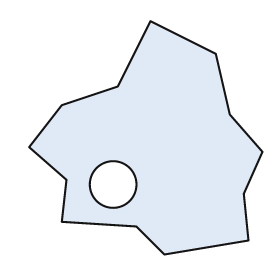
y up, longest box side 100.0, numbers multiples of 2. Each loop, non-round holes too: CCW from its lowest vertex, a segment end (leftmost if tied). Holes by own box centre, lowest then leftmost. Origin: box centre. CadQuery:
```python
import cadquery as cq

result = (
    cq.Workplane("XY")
    .moveTo(8.0, -50.0)
    .lineTo(44.0, -44.0)
    .lineTo(42.0, -24.0)
    .lineTo(50.0, -6.0)
    .lineTo(36.0, 10.0)
    .lineTo(30.0, 36.0)
    .lineTo(2.0, 50.0)
    .lineTo(-12.0, 22.0)
    .lineTo(-36.0, 14.0)
    .lineTo(-50.0, -4.0)
    .lineTo(-34.0, -18.0)
    .lineTo(-36.0, -36.0)
    .lineTo(-4.0, -38.0)
    .close()
    .moveTo(-14.0, -20.0)
    .circle(10.0)
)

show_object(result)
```